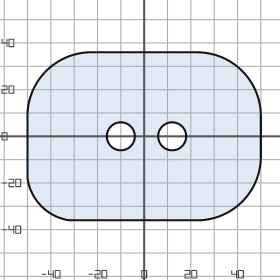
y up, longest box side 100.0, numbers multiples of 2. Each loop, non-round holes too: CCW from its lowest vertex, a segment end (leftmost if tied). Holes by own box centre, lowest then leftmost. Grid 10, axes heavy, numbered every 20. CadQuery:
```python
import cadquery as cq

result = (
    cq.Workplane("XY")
    .moveTo(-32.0, -36.0)
    .lineTo(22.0, -36.0)
    .threePointArc((42.0, -28.0), (50.0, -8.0))
    .lineTo(50.0, 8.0)
    .threePointArc((42.0, 28.0), (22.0, 36.0))
    .lineTo(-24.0, 36.0)
    .threePointArc((-42.0, 28.0), (-50.0, 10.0))
    .lineTo(-50.0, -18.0)
    .threePointArc((-44.0, -30.0), (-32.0, -36.0))
    .close()
    .moveTo(-10.0, 0.0)
    .circle(6.0)
    .moveTo(12.0, 0.0)
    .circle(6.0)
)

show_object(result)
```